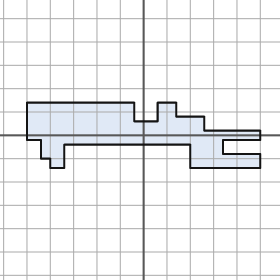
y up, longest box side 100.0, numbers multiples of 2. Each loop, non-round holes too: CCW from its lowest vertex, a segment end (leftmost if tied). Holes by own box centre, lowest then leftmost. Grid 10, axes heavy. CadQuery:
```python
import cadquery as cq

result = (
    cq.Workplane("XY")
    .moveTo(-40.0, -14.0)
    .lineTo(-34.0, -14.0)
    .lineTo(-34.0, -4.0)
    .lineTo(20.0, -4.0)
    .lineTo(20.0, -14.0)
    .lineTo(50.0, -14.0)
    .lineTo(50.0, -8.0)
    .lineTo(34.0, -8.0)
    .lineTo(34.0, -2.0)
    .lineTo(50.0, -2.0)
    .lineTo(50.0, 2.0)
    .lineTo(26.0, 2.0)
    .lineTo(26.0, 8.0)
    .lineTo(14.0, 8.0)
    .lineTo(14.0, 14.0)
    .lineTo(6.0, 14.0)
    .lineTo(6.0, 6.0)
    .lineTo(-4.0, 6.0)
    .lineTo(-4.0, 14.0)
    .lineTo(-50.0, 14.0)
    .lineTo(-50.0, -2.0)
    .lineTo(-44.0, -2.0)
    .lineTo(-44.0, -10.0)
    .lineTo(-40.0, -10.0)
    .close()
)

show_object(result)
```